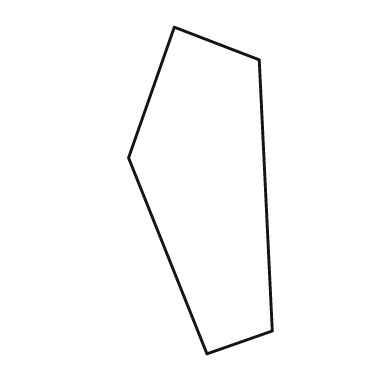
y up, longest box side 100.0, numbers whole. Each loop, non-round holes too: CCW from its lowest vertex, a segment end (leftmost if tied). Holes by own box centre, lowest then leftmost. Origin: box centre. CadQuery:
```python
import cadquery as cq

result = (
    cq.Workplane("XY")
    .moveTo(2.0, -50.0)
    .lineTo(22.0, -43.0)
    .lineTo(18.0, 40.0)
    .lineTo(-8.0, 50.0)
    .lineTo(-22.0, 10.0)
    .close()
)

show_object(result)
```